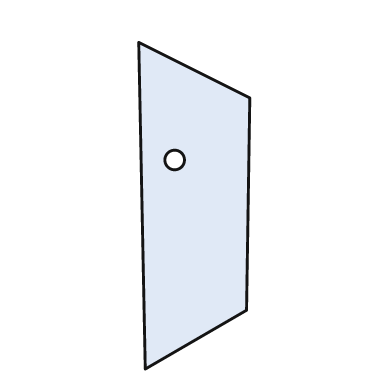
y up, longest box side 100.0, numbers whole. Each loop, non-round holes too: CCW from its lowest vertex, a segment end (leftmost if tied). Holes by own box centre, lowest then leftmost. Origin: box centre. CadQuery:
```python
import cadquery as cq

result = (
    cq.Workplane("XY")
    .moveTo(-15.0, -50.0)
    .lineTo(16.0, -32.0)
    .lineTo(17.0, 33.0)
    .lineTo(-17.0, 50.0)
    .close()
    .moveTo(-6.0, 14.0)
    .circle(3.0)
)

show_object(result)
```